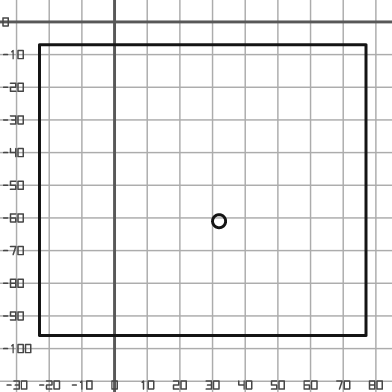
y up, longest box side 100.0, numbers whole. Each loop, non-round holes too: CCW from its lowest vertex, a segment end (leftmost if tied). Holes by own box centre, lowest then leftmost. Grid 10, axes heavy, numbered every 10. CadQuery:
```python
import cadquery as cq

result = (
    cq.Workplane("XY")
    .moveTo(-23.0, -96.0)
    .lineTo(77.0, -96.0)
    .lineTo(77.0, -7.0)
    .lineTo(-23.0, -7.0)
    .close()
    .moveTo(32.0, -61.0)
    .circle(2.0)
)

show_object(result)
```